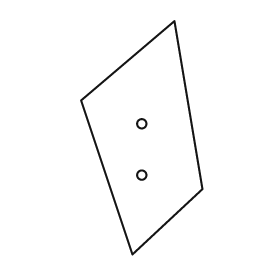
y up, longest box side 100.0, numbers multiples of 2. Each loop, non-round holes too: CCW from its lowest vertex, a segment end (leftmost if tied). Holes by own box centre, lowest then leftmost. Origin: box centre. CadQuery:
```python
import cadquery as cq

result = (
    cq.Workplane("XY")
    .moveTo(-4.0, -50.0)
    .lineTo(26.0, -22.0)
    .lineTo(14.0, 50.0)
    .lineTo(-26.0, 16.0)
    .close()
    .moveTo(0.0, -16.0)
    .circle(2.0)
    .moveTo(0.0, 6.0)
    .circle(2.0)
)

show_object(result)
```